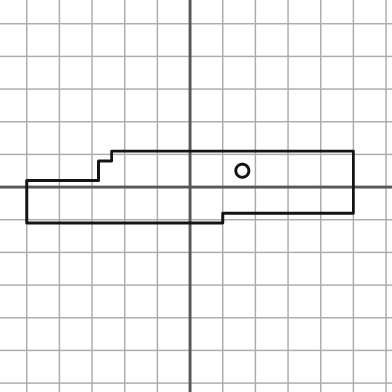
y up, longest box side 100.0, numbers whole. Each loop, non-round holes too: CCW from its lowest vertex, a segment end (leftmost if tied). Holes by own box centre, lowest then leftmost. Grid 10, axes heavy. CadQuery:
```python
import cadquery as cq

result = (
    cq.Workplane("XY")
    .moveTo(-50.0, -11.0)
    .lineTo(10.0, -11.0)
    .lineTo(10.0, -8.0)
    .lineTo(50.0, -8.0)
    .lineTo(50.0, 11.0)
    .lineTo(-24.0, 11.0)
    .lineTo(-24.0, 8.0)
    .lineTo(-28.0, 8.0)
    .lineTo(-28.0, 2.0)
    .lineTo(-50.0, 2.0)
    .close()
    .moveTo(16.0, 5.0)
    .circle(2.0)
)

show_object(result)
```